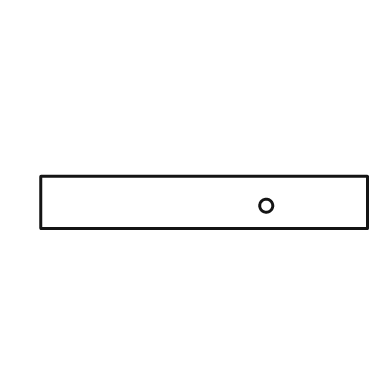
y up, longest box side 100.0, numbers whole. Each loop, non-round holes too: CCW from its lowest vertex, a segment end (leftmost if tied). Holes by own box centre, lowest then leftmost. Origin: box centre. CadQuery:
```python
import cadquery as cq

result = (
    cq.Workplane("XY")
    .moveTo(-50.0, -8.0)
    .lineTo(50.0, -8.0)
    .lineTo(50.0, 8.0)
    .lineTo(-50.0, 8.0)
    .close()
    .moveTo(19.0, -1.0)
    .circle(2.0)
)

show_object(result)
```